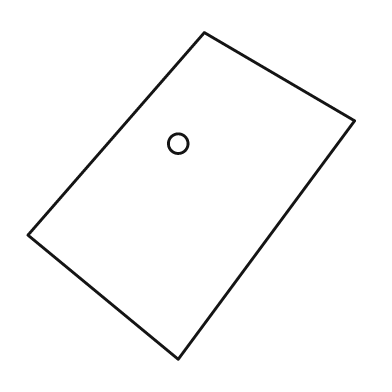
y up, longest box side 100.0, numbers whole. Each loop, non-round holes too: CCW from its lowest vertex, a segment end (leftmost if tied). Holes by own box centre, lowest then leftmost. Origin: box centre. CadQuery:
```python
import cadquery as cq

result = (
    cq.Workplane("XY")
    .moveTo(-4.0, -50.0)
    .lineTo(50.0, 23.0)
    .lineTo(4.0, 50.0)
    .lineTo(-50.0, -12.0)
    .close()
    .moveTo(-4.0, 16.0)
    .circle(3.0)
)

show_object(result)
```